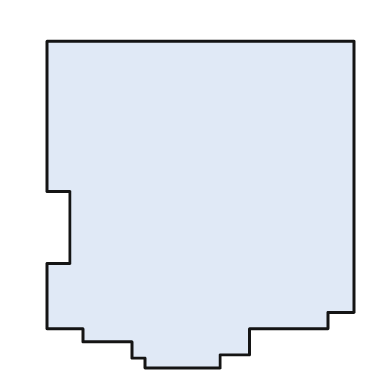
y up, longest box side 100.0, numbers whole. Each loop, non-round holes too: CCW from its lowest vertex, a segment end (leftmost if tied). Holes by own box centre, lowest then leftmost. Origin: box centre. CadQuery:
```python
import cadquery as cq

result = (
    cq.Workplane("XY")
    .moveTo(-17.0, -50.0)
    .lineTo(6.0, -50.0)
    .lineTo(6.0, -46.0)
    .lineTo(15.0, -46.0)
    .lineTo(15.0, -38.0)
    .lineTo(39.0, -38.0)
    .lineTo(39.0, -33.0)
    .lineTo(47.0, -33.0)
    .lineTo(47.0, 50.0)
    .lineTo(-47.0, 50.0)
    .lineTo(-47.0, 4.0)
    .lineTo(-40.0, 4.0)
    .lineTo(-40.0, -18.0)
    .lineTo(-47.0, -18.0)
    .lineTo(-47.0, -38.0)
    .lineTo(-36.0, -38.0)
    .lineTo(-36.0, -42.0)
    .lineTo(-21.0, -42.0)
    .lineTo(-21.0, -47.0)
    .lineTo(-17.0, -47.0)
    .close()
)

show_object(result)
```